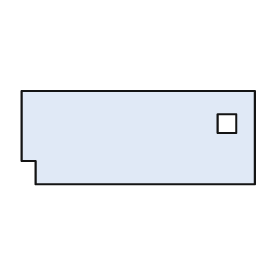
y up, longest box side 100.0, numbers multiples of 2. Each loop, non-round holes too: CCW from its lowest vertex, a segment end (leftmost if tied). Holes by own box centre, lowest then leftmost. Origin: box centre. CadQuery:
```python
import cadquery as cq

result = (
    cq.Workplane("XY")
    .moveTo(-44.0, -20.0)
    .lineTo(50.0, -20.0)
    .lineTo(50.0, 20.0)
    .lineTo(-50.0, 20.0)
    .lineTo(-50.0, -10.0)
    .lineTo(-44.0, -10.0)
    .close()
    .moveTo(34.0, 2.0)
    .lineTo(42.0, 2.0)
    .lineTo(42.0, 10.0)
    .lineTo(34.0, 10.0)
    .close()
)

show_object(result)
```